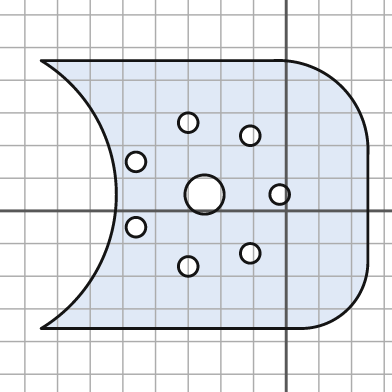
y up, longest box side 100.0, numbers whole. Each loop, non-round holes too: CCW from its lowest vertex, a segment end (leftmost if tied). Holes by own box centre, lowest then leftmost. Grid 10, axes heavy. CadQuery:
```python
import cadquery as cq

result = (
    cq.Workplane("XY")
    .moveTo(-75.0, -36.0)
    .lineTo(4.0, -36.0)
    .threePointArc((19.0, -30.0), (25.0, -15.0))
    .lineTo(25.0, 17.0)
    .threePointArc((17.0, 38.0), (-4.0, 46.0))
    .lineTo(-75.0, 46.0)
    .threePointArc((-52.0, 5.0), (-75.0, -36.0))
    .close()
    .moveTo(-30.0, -17.0)
    .circle(3.0)
    .moveTo(-11.0, -13.0)
    .circle(3.0)
    .moveTo(-46.0, -5.0)
    .circle(3.0)
    .moveTo(-25.0, 5.0)
    .circle(6.0)
    .moveTo(-2.0, 5.0)
    .circle(3.0)
    .moveTo(-46.0, 15.0)
    .circle(3.0)
    .moveTo(-11.0, 23.0)
    .circle(3.0)
    .moveTo(-30.0, 27.0)
    .circle(3.0)
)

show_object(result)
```